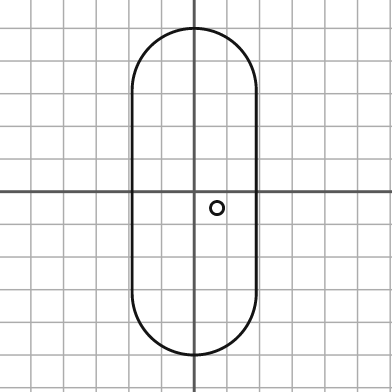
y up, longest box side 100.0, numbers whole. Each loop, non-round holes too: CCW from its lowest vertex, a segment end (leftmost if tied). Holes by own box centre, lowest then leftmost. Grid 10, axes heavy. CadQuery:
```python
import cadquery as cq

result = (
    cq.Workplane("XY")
    .moveTo(-19.0, -31.0)
    .threePointArc((0.0, -50.0), (19.0, -31.0))
    .lineTo(19.0, 31.0)
    .threePointArc((0.0, 50.0), (-19.0, 31.0))
    .close()
    .moveTo(7.0, -5.0)
    .circle(2.0)
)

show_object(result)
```